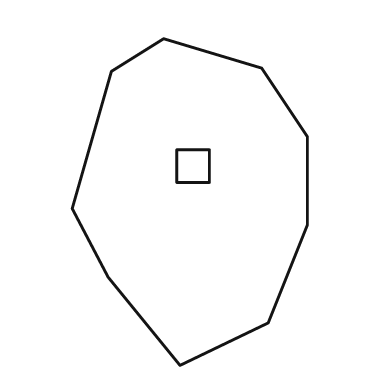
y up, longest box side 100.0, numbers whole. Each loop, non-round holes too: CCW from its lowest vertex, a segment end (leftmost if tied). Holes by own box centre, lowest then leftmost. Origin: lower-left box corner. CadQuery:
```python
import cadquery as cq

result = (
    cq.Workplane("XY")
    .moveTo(33.0, 0.0)
    .lineTo(60.0, 13.0)
    .lineTo(72.0, 43.0)
    .lineTo(72.0, 70.0)
    .lineTo(58.0, 91.0)
    .lineTo(28.0, 100.0)
    .lineTo(12.0, 90.0)
    .lineTo(0.0, 48.0)
    .lineTo(11.0, 27.0)
    .close()
    .moveTo(32.0, 56.0)
    .lineTo(42.0, 56.0)
    .lineTo(42.0, 66.0)
    .lineTo(32.0, 66.0)
    .close()
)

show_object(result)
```